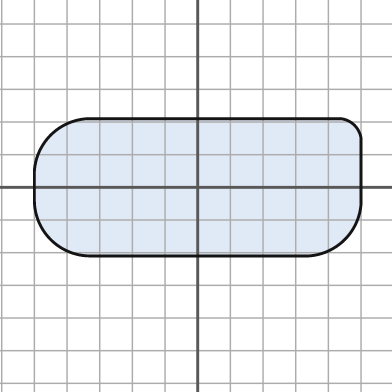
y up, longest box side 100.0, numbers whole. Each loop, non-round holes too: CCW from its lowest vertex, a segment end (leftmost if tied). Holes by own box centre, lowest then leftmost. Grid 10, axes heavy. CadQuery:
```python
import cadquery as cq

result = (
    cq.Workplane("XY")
    .moveTo(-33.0, -21.0)
    .lineTo(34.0, -21.0)
    .threePointArc((45.0, -16.0), (50.0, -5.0))
    .lineTo(50.0, 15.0)
    .threePointArc((48.0, 19.0), (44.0, 21.0))
    .lineTo(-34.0, 21.0)
    .threePointArc((-45.0, 16.0), (-50.0, 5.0))
    .lineTo(-50.0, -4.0)
    .threePointArc((-45.0, -16.0), (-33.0, -21.0))
    .close()
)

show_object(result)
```